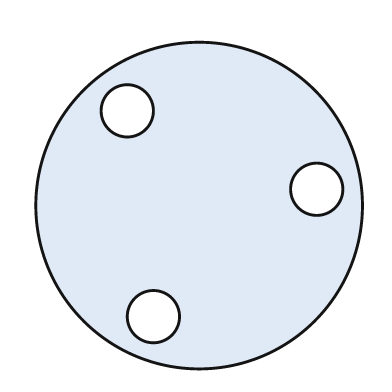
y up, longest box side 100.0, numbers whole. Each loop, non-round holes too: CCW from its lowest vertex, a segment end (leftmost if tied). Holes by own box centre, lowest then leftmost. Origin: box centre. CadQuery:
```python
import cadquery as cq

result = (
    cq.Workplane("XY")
    .moveTo(0.0, 0.0)
    .circle(50.0)
    .moveTo(-14.0, -34.0)
    .circle(8.0)
    .moveTo(36.0, 5.0)
    .circle(8.0)
    .moveTo(-22.0, 29.0)
    .circle(8.0)
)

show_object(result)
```